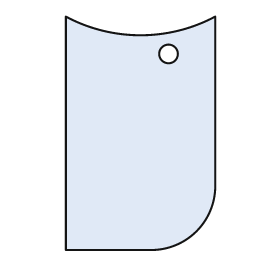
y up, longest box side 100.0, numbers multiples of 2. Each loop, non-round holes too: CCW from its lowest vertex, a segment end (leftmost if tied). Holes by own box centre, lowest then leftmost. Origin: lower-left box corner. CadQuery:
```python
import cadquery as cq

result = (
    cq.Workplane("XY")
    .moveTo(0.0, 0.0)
    .lineTo(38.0, 0.0)
    .threePointArc((56.0, 8.0), (64.0, 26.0))
    .lineTo(64.0, 100.0)
    .threePointArc((32.0, 92.0), (0.0, 100.0))
    .close()
    .moveTo(44.0, 84.0)
    .circle(4.0)
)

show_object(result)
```